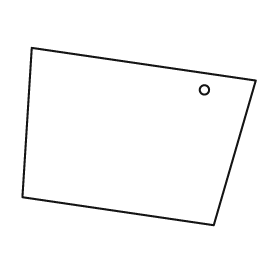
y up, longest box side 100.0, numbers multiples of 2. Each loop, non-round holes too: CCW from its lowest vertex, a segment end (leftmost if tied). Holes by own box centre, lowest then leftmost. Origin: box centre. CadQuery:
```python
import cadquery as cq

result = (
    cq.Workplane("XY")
    .moveTo(32.0, -38.0)
    .lineTo(50.0, 24.0)
    .lineTo(-46.0, 38.0)
    .lineTo(-50.0, -26.0)
    .close()
    .moveTo(28.0, 20.0)
    .circle(2.0)
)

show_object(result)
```